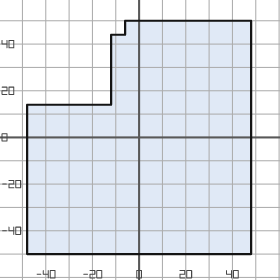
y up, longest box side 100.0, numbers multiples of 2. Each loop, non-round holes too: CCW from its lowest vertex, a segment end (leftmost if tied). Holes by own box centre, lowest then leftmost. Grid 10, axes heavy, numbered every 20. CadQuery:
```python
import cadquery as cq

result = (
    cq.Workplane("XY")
    .moveTo(-48.0, -50.0)
    .lineTo(48.0, -50.0)
    .lineTo(48.0, 50.0)
    .lineTo(-6.0, 50.0)
    .lineTo(-6.0, 44.0)
    .lineTo(-12.0, 44.0)
    .lineTo(-12.0, 14.0)
    .lineTo(-48.0, 14.0)
    .close()
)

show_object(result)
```